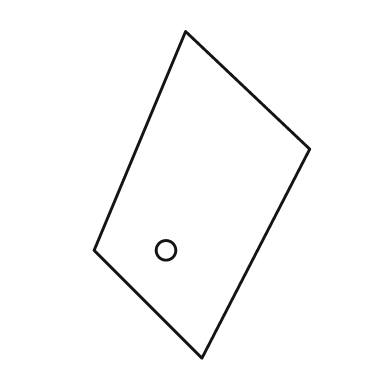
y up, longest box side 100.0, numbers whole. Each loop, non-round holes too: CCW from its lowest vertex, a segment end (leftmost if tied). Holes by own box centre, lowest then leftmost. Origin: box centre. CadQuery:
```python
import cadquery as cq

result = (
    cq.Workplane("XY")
    .moveTo(0.0, -50.0)
    .lineTo(33.0, 14.0)
    .lineTo(-5.0, 50.0)
    .lineTo(-33.0, -17.0)
    .close()
    .moveTo(-11.0, -17.0)
    .circle(3.0)
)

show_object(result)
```